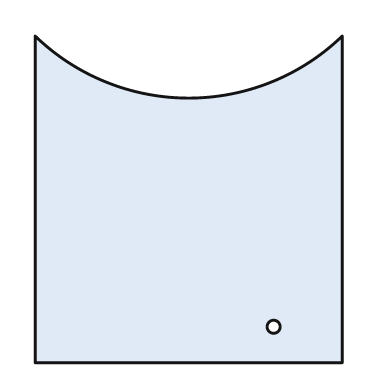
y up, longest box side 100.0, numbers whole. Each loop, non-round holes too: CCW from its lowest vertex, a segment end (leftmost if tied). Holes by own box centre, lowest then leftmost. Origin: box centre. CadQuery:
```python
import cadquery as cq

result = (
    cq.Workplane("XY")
    .moveTo(-47.0, -50.0)
    .lineTo(47.0, -50.0)
    .lineTo(47.0, 50.0)
    .threePointArc((0.0, 31.0), (-47.0, 50.0))
    .close()
    .moveTo(26.0, -39.0)
    .circle(2.0)
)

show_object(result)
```